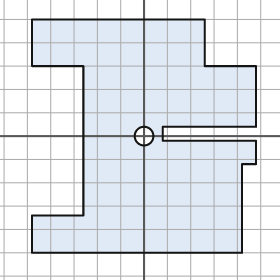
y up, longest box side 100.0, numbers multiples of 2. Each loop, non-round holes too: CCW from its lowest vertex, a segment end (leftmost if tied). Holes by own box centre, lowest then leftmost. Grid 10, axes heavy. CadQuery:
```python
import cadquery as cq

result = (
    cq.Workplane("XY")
    .moveTo(-48.0, -50.0)
    .lineTo(42.0, -50.0)
    .lineTo(42.0, -12.0)
    .lineTo(48.0, -12.0)
    .lineTo(48.0, -2.0)
    .lineTo(8.0, -2.0)
    .lineTo(8.0, 4.0)
    .lineTo(48.0, 4.0)
    .lineTo(48.0, 30.0)
    .lineTo(26.0, 30.0)
    .lineTo(26.0, 50.0)
    .lineTo(-48.0, 50.0)
    .lineTo(-48.0, 30.0)
    .lineTo(-26.0, 30.0)
    .lineTo(-26.0, -34.0)
    .lineTo(-48.0, -34.0)
    .close()
    .moveTo(0.0, 0.0)
    .circle(4.0)
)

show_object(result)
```